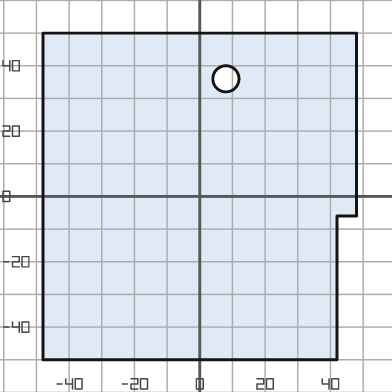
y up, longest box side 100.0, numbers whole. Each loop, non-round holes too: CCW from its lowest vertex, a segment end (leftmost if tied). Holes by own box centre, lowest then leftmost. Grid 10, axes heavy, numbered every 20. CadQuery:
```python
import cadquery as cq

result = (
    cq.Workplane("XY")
    .moveTo(-48.0, -50.0)
    .lineTo(42.0, -50.0)
    .lineTo(42.0, -6.0)
    .lineTo(48.0, -6.0)
    .lineTo(48.0, 50.0)
    .lineTo(-48.0, 50.0)
    .close()
    .moveTo(8.0, 36.0)
    .circle(4.0)
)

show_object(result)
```